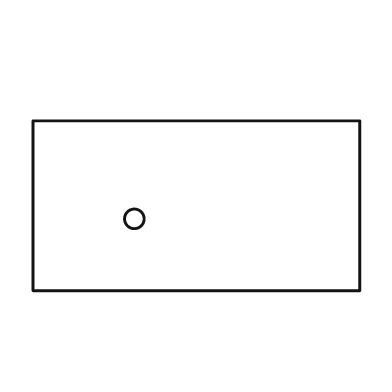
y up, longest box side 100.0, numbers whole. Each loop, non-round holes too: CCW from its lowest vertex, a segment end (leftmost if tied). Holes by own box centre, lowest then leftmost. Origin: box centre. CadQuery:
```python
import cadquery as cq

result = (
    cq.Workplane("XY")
    .moveTo(-50.0, -26.0)
    .lineTo(50.0, -26.0)
    .lineTo(50.0, 26.0)
    .lineTo(-50.0, 26.0)
    .close()
    .moveTo(-19.0, -4.0)
    .circle(3.0)
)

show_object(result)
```